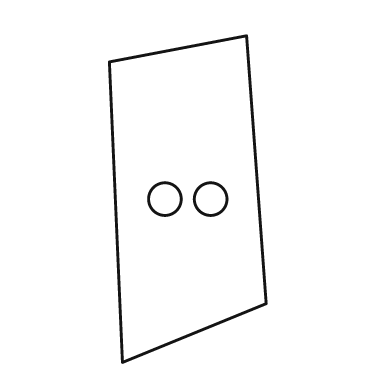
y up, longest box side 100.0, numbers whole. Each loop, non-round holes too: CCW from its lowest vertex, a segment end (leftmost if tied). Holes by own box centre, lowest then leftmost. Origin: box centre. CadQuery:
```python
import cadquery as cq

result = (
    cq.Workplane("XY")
    .moveTo(-20.0, -50.0)
    .lineTo(24.0, -32.0)
    .lineTo(18.0, 50.0)
    .lineTo(-24.0, 42.0)
    .close()
    .moveTo(-7.0, 0.0)
    .circle(5.0)
    .moveTo(7.0, 0.0)
    .circle(5.0)
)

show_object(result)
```